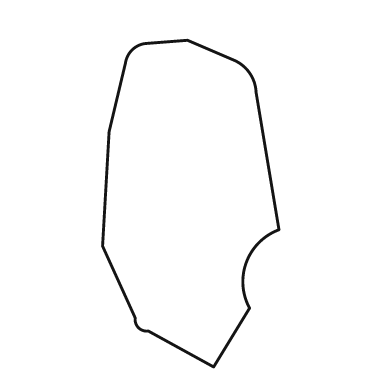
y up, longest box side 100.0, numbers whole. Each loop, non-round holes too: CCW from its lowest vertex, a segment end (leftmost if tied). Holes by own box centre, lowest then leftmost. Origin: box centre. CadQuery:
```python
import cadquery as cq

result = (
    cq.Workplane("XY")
    .moveTo(7.0, -50.0)
    .lineTo(18.0, -32.0)
    .threePointArc((17.0, -18.0), (27.0, -8.0))
    .lineTo(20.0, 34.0)
    .threePointArc((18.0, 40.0), (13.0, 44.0))
    .lineTo(-1.0, 50.0)
    .lineTo(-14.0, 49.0)
    .threePointArc((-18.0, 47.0), (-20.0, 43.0))
    .lineTo(-25.0, 22.0)
    .lineTo(-27.0, -13.0)
    .lineTo(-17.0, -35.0)
    .threePointArc((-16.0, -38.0), (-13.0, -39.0))
    .close()
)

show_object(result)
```